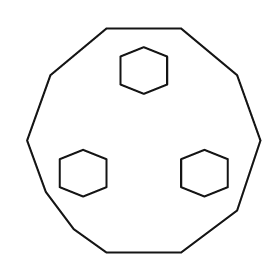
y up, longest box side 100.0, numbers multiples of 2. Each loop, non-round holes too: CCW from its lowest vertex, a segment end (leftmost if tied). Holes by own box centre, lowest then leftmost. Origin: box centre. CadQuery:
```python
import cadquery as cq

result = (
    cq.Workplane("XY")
    .moveTo(-16.0, -48.0)
    .lineTo(16.0, -48.0)
    .lineTo(40.0, -30.0)
    .lineTo(50.0, 0.0)
    .lineTo(40.0, 28.0)
    .lineTo(16.0, 48.0)
    .lineTo(-16.0, 48.0)
    .lineTo(-40.0, 28.0)
    .lineTo(-50.0, 0.0)
    .lineTo(-42.0, -22.0)
    .lineTo(-30.0, -38.0)
    .close()
    .moveTo(-26.0, -24.0)
    .lineTo(-16.0, -20.0)
    .lineTo(-16.0, -8.0)
    .lineTo(-26.0, -4.0)
    .lineTo(-36.0, -8.0)
    .lineTo(-36.0, -20.0)
    .close()
    .moveTo(26.0, -24.0)
    .lineTo(36.0, -20.0)
    .lineTo(36.0, -8.0)
    .lineTo(26.0, -4.0)
    .lineTo(16.0, -8.0)
    .lineTo(16.0, -20.0)
    .close()
    .moveTo(0.0, 20.0)
    .lineTo(10.0, 24.0)
    .lineTo(10.0, 36.0)
    .lineTo(0.0, 40.0)
    .lineTo(-10.0, 36.0)
    .lineTo(-10.0, 24.0)
    .close()
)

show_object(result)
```